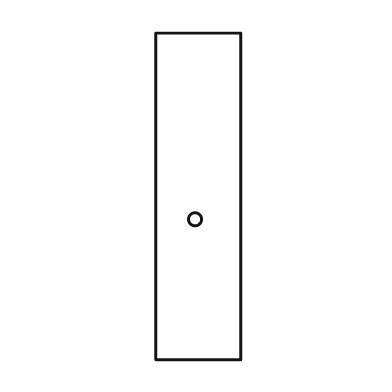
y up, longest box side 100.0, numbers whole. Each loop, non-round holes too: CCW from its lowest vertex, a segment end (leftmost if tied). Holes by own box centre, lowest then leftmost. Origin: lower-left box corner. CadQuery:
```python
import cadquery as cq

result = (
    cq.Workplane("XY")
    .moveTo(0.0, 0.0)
    .lineTo(26.0, 0.0)
    .lineTo(26.0, 100.0)
    .lineTo(0.0, 100.0)
    .close()
    .moveTo(12.0, 43.0)
    .circle(2.0)
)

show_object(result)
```